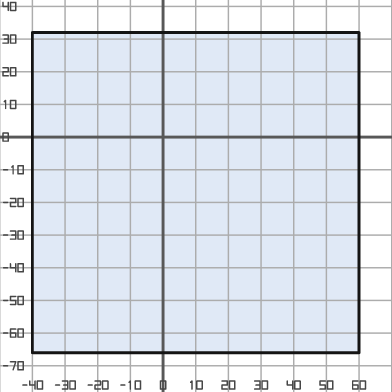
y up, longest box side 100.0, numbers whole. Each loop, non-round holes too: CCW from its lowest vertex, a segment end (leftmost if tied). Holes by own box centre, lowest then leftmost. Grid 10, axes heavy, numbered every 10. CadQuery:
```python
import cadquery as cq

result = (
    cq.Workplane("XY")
    .moveTo(-40.0, -66.0)
    .lineTo(60.0, -66.0)
    .lineTo(60.0, 32.0)
    .lineTo(-40.0, 32.0)
    .close()
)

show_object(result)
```